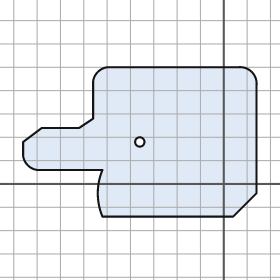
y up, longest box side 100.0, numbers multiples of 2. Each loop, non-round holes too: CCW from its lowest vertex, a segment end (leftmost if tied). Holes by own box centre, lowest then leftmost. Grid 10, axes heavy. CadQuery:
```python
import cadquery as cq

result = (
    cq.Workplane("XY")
    .moveTo(-52.0, -14.0)
    .lineTo(4.0, -14.0)
    .lineTo(14.0, -4.0)
    .lineTo(14.0, 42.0)
    .threePointArc((12.0, 48.0), (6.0, 50.0))
    .lineTo(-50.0, 50.0)
    .threePointArc((-54.0, 48.0), (-56.0, 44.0))
    .lineTo(-56.0, 28.0)
    .lineTo(-62.0, 24.0)
    .lineTo(-78.0, 24.0)
    .lineTo(-86.0, 18.0)
    .lineTo(-86.0, 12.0)
    .threePointArc((-84.0, 8.0), (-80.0, 6.0))
    .lineTo(-52.0, 6.0)
    .threePointArc((-54.0, -4.0), (-52.0, -14.0))
    .close()
    .moveTo(-36.0, 18.0)
    .circle(2.0)
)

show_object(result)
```